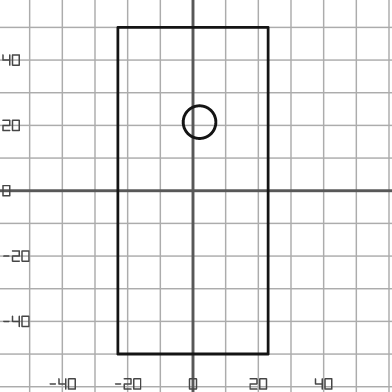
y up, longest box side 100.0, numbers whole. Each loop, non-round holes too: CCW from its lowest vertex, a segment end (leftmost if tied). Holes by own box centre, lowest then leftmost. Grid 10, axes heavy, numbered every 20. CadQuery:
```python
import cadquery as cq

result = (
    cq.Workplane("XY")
    .moveTo(-23.0, -50.0)
    .lineTo(23.0, -50.0)
    .lineTo(23.0, 50.0)
    .lineTo(-23.0, 50.0)
    .close()
    .moveTo(2.0, 21.0)
    .circle(5.0)
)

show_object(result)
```